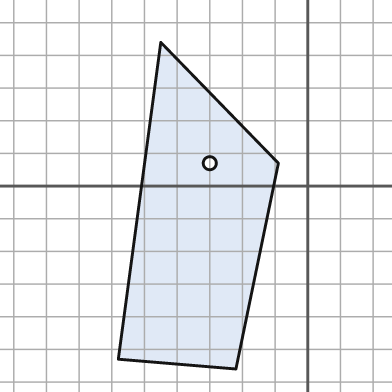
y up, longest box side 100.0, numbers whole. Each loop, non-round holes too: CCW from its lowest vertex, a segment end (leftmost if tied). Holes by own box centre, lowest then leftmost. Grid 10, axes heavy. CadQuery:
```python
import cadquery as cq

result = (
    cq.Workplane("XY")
    .moveTo(-22.0, -56.0)
    .lineTo(-9.0, 7.0)
    .lineTo(-45.0, 44.0)
    .lineTo(-58.0, -53.0)
    .close()
    .moveTo(-30.0, 7.0)
    .circle(2.0)
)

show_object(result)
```